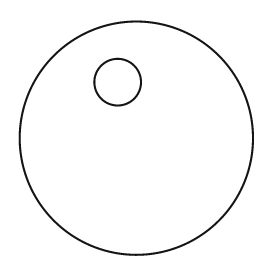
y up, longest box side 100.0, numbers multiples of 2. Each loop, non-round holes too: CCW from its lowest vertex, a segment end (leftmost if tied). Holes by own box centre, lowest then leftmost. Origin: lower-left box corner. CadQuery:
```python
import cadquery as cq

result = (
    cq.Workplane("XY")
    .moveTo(50.0, 50.0)
    .circle(50.0)
    .moveTo(42.0, 74.0)
    .circle(10.0)
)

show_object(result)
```